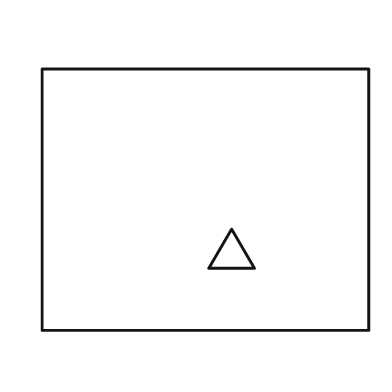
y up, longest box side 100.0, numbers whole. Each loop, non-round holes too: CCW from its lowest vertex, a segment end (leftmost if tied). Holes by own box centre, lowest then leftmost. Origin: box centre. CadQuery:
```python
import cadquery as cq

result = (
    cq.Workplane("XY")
    .moveTo(-50.0, -40.0)
    .lineTo(50.0, -40.0)
    .lineTo(50.0, 40.0)
    .lineTo(-50.0, 40.0)
    .close()
    .moveTo(1.0, -21.0)
    .lineTo(15.0, -21.0)
    .lineTo(8.0, -9.0)
    .close()
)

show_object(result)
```